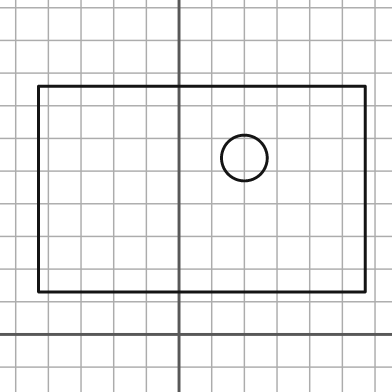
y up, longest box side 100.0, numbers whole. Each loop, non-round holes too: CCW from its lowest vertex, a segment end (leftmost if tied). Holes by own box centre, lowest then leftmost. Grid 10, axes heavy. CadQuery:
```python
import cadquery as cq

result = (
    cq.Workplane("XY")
    .moveTo(-43.0, 13.0)
    .lineTo(57.0, 13.0)
    .lineTo(57.0, 76.0)
    .lineTo(-43.0, 76.0)
    .close()
    .moveTo(20.0, 54.0)
    .circle(7.0)
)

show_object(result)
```